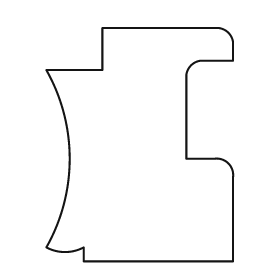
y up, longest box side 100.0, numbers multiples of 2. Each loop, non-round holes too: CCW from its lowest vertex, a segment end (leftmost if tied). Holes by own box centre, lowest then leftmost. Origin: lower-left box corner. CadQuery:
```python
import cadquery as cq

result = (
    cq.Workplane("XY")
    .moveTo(16.0, 0.0)
    .lineTo(80.0, 0.0)
    .lineTo(80.0, 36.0)
    .threePointArc((78.0, 42.0), (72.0, 44.0))
    .lineTo(60.0, 44.0)
    .lineTo(60.0, 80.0)
    .threePointArc((62.0, 84.0), (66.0, 86.0))
    .lineTo(80.0, 86.0)
    .lineTo(80.0, 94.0)
    .threePointArc((78.0, 98.0), (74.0, 100.0))
    .lineTo(24.0, 100.0)
    .lineTo(24.0, 82.0)
    .lineTo(0.0, 82.0)
    .threePointArc((10.0, 44.0), (0.0, 6.0))
    .threePointArc((8.0, 4.0), (16.0, 6.0))
    .close()
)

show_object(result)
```